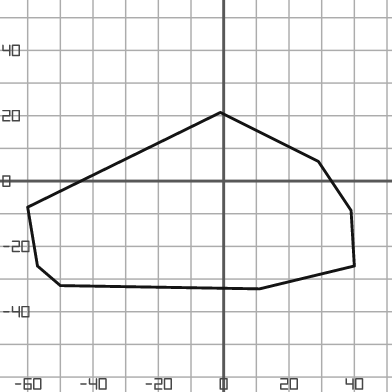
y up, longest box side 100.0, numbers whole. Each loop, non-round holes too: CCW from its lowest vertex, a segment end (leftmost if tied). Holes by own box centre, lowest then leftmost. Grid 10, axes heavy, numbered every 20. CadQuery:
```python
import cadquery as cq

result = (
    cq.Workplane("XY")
    .moveTo(11.0, -33.0)
    .lineTo(40.0, -26.0)
    .lineTo(39.0, -9.0)
    .lineTo(29.0, 6.0)
    .lineTo(-1.0, 21.0)
    .lineTo(-60.0, -8.0)
    .lineTo(-57.0, -26.0)
    .lineTo(-50.0, -32.0)
    .close()
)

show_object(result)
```